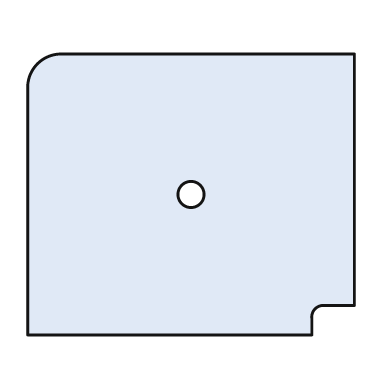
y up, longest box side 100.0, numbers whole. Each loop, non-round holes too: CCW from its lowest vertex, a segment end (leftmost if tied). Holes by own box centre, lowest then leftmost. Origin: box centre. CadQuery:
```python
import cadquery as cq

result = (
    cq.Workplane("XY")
    .moveTo(-50.0, -43.0)
    .lineTo(37.0, -43.0)
    .lineTo(37.0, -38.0)
    .threePointArc((38.0, -35.0), (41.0, -34.0))
    .lineTo(50.0, -34.0)
    .lineTo(50.0, 43.0)
    .lineTo(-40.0, 43.0)
    .threePointArc((-47.0, 40.0), (-50.0, 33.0))
    .close()
    .moveTo(0.0, 0.0)
    .circle(4.0)
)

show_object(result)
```